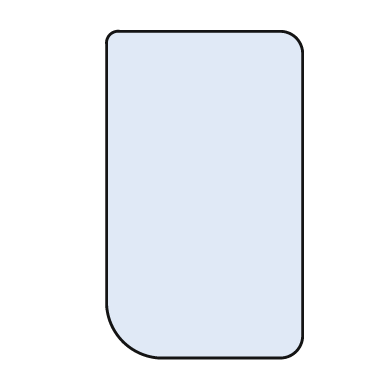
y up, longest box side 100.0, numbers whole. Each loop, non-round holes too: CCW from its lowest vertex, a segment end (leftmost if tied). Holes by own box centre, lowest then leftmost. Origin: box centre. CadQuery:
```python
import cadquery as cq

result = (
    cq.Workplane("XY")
    .moveTo(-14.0, -50.0)
    .lineTo(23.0, -50.0)
    .threePointArc((28.0, -48.0), (30.0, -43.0))
    .lineTo(30.0, 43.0)
    .threePointArc((28.0, 48.0), (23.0, 50.0))
    .lineTo(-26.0, 50.0)
    .threePointArc((-29.0, 49.0), (-30.0, 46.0))
    .lineTo(-30.0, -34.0)
    .threePointArc((-25.0, -45.0), (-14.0, -50.0))
    .close()
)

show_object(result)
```